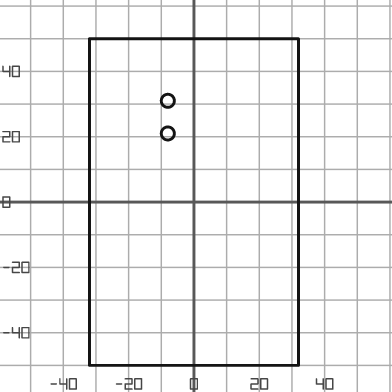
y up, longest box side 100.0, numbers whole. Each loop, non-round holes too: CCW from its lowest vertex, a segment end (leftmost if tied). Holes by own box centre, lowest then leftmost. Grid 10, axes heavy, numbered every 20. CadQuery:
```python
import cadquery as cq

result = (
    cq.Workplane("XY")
    .moveTo(-32.0, -50.0)
    .lineTo(32.0, -50.0)
    .lineTo(32.0, 50.0)
    .lineTo(-32.0, 50.0)
    .close()
    .moveTo(-8.0, 21.0)
    .circle(2.0)
    .moveTo(-8.0, 31.0)
    .circle(2.0)
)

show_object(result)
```